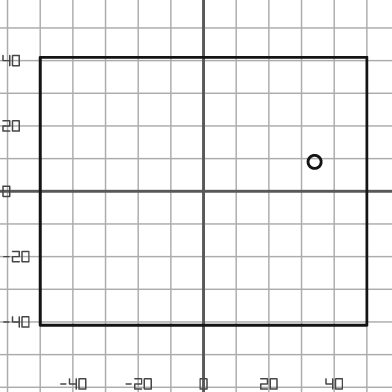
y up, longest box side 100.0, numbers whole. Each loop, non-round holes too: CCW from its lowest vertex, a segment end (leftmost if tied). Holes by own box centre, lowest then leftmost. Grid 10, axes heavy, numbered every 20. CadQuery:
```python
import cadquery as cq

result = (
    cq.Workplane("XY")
    .moveTo(-50.0, -41.0)
    .lineTo(50.0, -41.0)
    .lineTo(50.0, 41.0)
    .lineTo(-50.0, 41.0)
    .close()
    .moveTo(34.0, 9.0)
    .circle(2.0)
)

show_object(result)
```